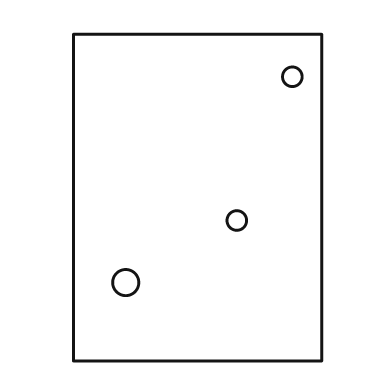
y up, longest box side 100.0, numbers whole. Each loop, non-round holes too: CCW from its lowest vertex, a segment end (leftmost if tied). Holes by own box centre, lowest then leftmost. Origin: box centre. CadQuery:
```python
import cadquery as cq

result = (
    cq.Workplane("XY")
    .moveTo(-38.0, -50.0)
    .lineTo(38.0, -50.0)
    .lineTo(38.0, 50.0)
    .lineTo(-38.0, 50.0)
    .close()
    .moveTo(-22.0, -26.0)
    .circle(4.0)
    .moveTo(12.0, -7.0)
    .circle(3.0)
    .moveTo(29.0, 37.0)
    .circle(3.0)
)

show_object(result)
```